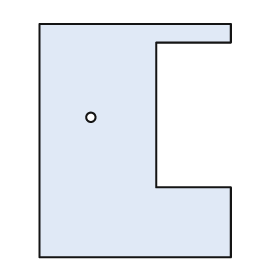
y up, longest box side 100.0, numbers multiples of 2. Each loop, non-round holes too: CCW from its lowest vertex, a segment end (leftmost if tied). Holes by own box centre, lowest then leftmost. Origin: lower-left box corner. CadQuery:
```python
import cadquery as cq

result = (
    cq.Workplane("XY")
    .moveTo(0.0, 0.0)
    .lineTo(82.0, 0.0)
    .lineTo(82.0, 30.0)
    .lineTo(50.0, 30.0)
    .lineTo(50.0, 92.0)
    .lineTo(82.0, 92.0)
    .lineTo(82.0, 100.0)
    .lineTo(0.0, 100.0)
    .close()
    .moveTo(22.0, 60.0)
    .circle(2.0)
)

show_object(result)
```